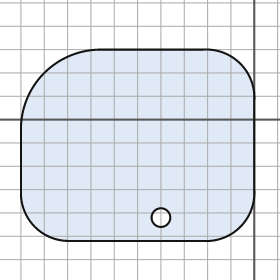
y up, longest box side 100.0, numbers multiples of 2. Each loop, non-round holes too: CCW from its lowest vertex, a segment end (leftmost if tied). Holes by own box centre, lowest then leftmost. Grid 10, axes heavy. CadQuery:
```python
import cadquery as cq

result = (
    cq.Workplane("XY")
    .moveTo(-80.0, -52.0)
    .lineTo(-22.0, -52.0)
    .threePointArc((-6.0, -46.0), (0.0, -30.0))
    .lineTo(0.0, 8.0)
    .threePointArc((-6.0, 24.0), (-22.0, 30.0))
    .lineTo(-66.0, 30.0)
    .threePointArc((-90.0, 20.0), (-100.0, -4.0))
    .lineTo(-100.0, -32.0)
    .threePointArc((-94.0, -46.0), (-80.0, -52.0))
    .close()
    .moveTo(-40.0, -42.0)
    .circle(4.0)
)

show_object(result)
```